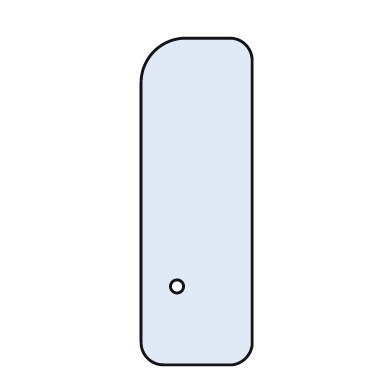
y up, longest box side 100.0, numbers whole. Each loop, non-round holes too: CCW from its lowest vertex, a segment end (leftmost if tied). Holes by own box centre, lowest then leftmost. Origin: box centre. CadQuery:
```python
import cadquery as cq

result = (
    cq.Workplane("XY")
    .moveTo(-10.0, -50.0)
    .lineTo(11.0, -50.0)
    .threePointArc((15.0, -48.0), (17.0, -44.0))
    .lineTo(17.0, 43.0)
    .threePointArc((15.0, 48.0), (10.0, 50.0))
    .lineTo(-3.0, 50.0)
    .threePointArc((-13.0, 46.0), (-17.0, 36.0))
    .lineTo(-17.0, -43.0)
    .threePointArc((-15.0, -48.0), (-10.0, -50.0))
    .close()
    .moveTo(-6.0, -26.0)
    .circle(2.0)
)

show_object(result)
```